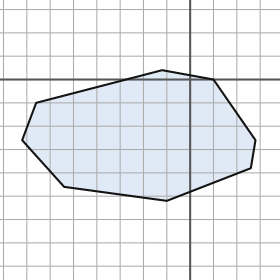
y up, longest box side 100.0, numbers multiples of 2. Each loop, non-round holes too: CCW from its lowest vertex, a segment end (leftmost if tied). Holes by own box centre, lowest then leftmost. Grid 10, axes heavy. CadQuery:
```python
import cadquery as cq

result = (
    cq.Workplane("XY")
    .moveTo(-10.0, -52.0)
    .lineTo(26.0, -38.0)
    .lineTo(28.0, -26.0)
    .lineTo(10.0, 0.0)
    .lineTo(-12.0, 4.0)
    .lineTo(-66.0, -10.0)
    .lineTo(-72.0, -26.0)
    .lineTo(-54.0, -46.0)
    .close()
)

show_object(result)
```